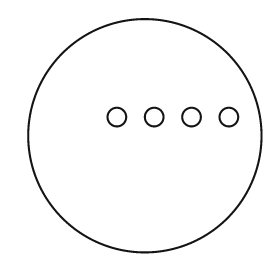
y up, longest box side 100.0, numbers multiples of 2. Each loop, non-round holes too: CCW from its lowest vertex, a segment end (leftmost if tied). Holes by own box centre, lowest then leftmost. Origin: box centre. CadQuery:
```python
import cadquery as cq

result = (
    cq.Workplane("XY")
    .moveTo(0.0, 0.0)
    .circle(50.0)
    .moveTo(-12.0, 8.0)
    .circle(4.0)
    .moveTo(4.0, 8.0)
    .circle(4.0)
    .moveTo(20.0, 8.0)
    .circle(4.0)
    .moveTo(36.0, 8.0)
    .circle(4.0)
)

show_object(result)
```